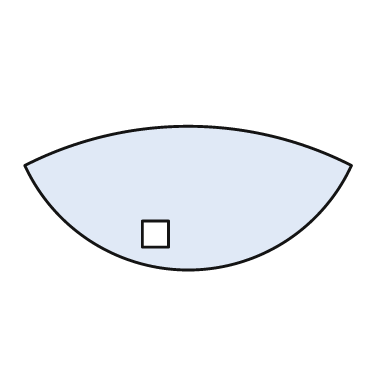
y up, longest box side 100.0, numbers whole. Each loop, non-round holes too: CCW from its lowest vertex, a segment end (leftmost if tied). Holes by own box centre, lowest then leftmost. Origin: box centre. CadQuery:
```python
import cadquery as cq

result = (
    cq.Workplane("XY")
    .moveTo(-50.0, 10.0)
    .threePointArc((0.0, -22.0), (50.0, 10.0))
    .threePointArc((0.0, 22.0), (-50.0, 10.0))
    .close()
    .moveTo(-14.0, -15.0)
    .lineTo(-6.0, -15.0)
    .lineTo(-6.0, -7.0)
    .lineTo(-14.0, -7.0)
    .close()
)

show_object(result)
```